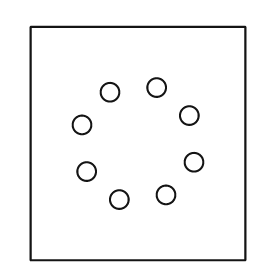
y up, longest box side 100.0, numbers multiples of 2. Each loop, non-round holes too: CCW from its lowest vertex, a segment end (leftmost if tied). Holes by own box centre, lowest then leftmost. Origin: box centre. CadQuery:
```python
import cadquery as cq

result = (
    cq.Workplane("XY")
    .moveTo(-46.0, -50.0)
    .lineTo(46.0, -50.0)
    .lineTo(46.0, 50.0)
    .lineTo(-46.0, 50.0)
    .close()
    .moveTo(-8.0, -24.0)
    .circle(4.0)
    .moveTo(12.0, -22.0)
    .circle(4.0)
    .moveTo(-22.0, -12.0)
    .circle(4.0)
    .moveTo(24.0, -8.0)
    .circle(4.0)
    .moveTo(-24.0, 8.0)
    .circle(4.0)
    .moveTo(22.0, 12.0)
    .circle(4.0)
    .moveTo(-12.0, 22.0)
    .circle(4.0)
    .moveTo(8.0, 24.0)
    .circle(4.0)
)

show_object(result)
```